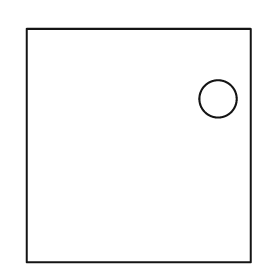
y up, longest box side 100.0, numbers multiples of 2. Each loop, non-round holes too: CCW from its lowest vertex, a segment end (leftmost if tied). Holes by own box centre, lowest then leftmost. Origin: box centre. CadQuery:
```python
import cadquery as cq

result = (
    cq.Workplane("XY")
    .moveTo(-48.0, -50.0)
    .lineTo(48.0, -50.0)
    .lineTo(48.0, 50.0)
    .lineTo(-48.0, 50.0)
    .close()
    .moveTo(34.0, 20.0)
    .circle(8.0)
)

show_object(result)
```